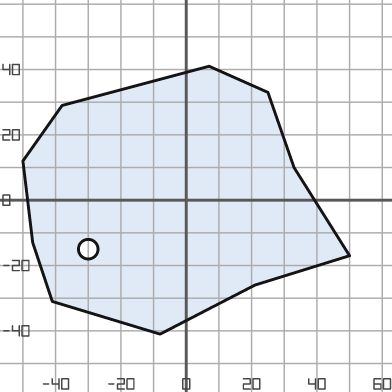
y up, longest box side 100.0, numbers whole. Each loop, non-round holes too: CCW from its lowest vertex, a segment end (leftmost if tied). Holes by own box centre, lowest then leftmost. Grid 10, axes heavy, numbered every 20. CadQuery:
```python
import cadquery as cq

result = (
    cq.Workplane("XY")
    .moveTo(-8.0, -41.0)
    .lineTo(21.0, -26.0)
    .lineTo(50.0, -17.0)
    .lineTo(33.0, 10.0)
    .lineTo(25.0, 33.0)
    .lineTo(7.0, 41.0)
    .lineTo(-38.0, 29.0)
    .lineTo(-50.0, 12.0)
    .lineTo(-47.0, -13.0)
    .lineTo(-41.0, -31.0)
    .close()
    .moveTo(-30.0, -15.0)
    .circle(3.0)
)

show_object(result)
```